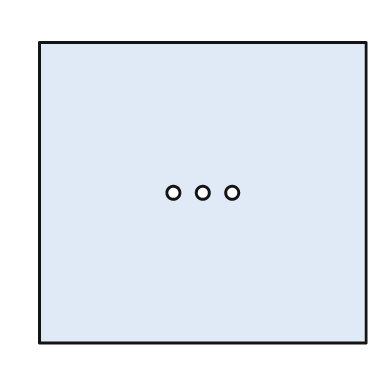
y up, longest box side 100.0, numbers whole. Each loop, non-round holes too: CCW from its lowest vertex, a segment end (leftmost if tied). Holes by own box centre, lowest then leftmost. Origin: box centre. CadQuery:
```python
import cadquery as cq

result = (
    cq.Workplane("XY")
    .moveTo(-50.0, -46.0)
    .lineTo(50.0, -46.0)
    .lineTo(50.0, 46.0)
    .lineTo(-50.0, 46.0)
    .close()
    .moveTo(-9.0, 0.0)
    .circle(2.0)
    .moveTo(0.0, 0.0)
    .circle(2.0)
    .moveTo(9.0, 0.0)
    .circle(2.0)
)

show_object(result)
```